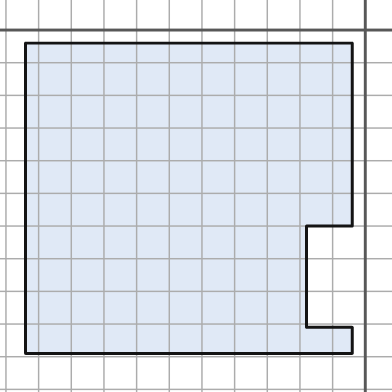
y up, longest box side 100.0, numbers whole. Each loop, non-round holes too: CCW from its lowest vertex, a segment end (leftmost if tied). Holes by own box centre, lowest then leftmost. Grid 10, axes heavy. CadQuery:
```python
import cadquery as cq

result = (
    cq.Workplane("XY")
    .moveTo(-104.0, -99.0)
    .lineTo(-4.0, -99.0)
    .lineTo(-4.0, -91.0)
    .lineTo(-18.0, -91.0)
    .lineTo(-18.0, -60.0)
    .lineTo(-4.0, -60.0)
    .lineTo(-4.0, -4.0)
    .lineTo(-104.0, -4.0)
    .close()
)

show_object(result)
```